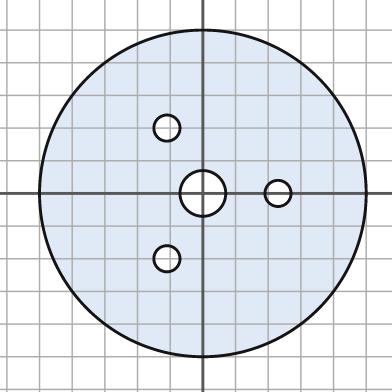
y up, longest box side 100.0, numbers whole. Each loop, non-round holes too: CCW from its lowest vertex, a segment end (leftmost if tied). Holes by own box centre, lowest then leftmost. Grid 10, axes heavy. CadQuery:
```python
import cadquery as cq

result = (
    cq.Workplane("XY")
    .moveTo(0.0, 0.0)
    .circle(50.0)
    .moveTo(-11.0, -20.0)
    .circle(4.0)
    .moveTo(0.0, 0.0)
    .circle(7.0)
    .moveTo(23.0, 0.0)
    .circle(4.0)
    .moveTo(-11.0, 20.0)
    .circle(4.0)
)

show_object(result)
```